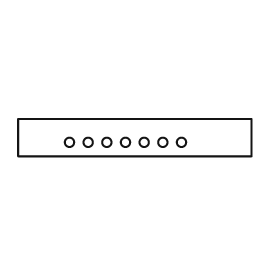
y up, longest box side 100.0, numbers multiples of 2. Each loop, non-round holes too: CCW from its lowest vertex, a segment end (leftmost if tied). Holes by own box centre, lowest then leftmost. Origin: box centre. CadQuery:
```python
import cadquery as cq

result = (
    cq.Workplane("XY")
    .moveTo(-50.0, -8.0)
    .lineTo(50.0, -8.0)
    .lineTo(50.0, 8.0)
    .lineTo(-50.0, 8.0)
    .close()
    .moveTo(-28.0, -2.0)
    .circle(2.0)
    .moveTo(-20.0, -2.0)
    .circle(2.0)
    .moveTo(-12.0, -2.0)
    .circle(2.0)
    .moveTo(-4.0, -2.0)
    .circle(2.0)
    .moveTo(4.0, -2.0)
    .circle(2.0)
    .moveTo(12.0, -2.0)
    .circle(2.0)
    .moveTo(20.0, -2.0)
    .circle(2.0)
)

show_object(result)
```